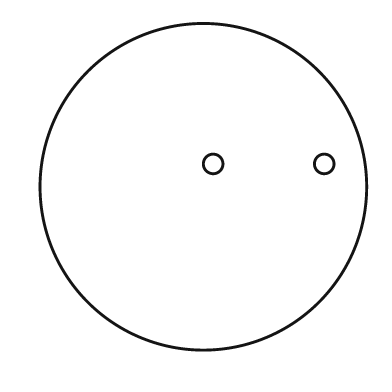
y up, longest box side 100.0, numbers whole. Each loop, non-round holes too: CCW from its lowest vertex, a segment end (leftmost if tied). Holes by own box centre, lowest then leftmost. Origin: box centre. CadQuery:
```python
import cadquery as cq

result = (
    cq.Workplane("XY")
    .moveTo(0.0, 0.0)
    .circle(50.0)
    .moveTo(3.0, 7.0)
    .circle(3.0)
    .moveTo(37.0, 7.0)
    .circle(3.0)
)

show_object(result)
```